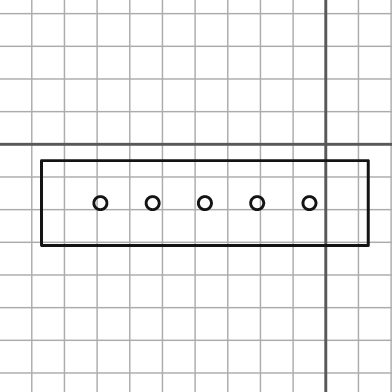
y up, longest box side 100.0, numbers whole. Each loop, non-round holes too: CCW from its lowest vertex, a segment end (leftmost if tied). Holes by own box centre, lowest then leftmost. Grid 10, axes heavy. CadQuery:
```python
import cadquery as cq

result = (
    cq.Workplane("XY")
    .moveTo(-87.0, -31.0)
    .lineTo(13.0, -31.0)
    .lineTo(13.0, -5.0)
    .lineTo(-87.0, -5.0)
    .close()
    .moveTo(-69.0, -18.0)
    .circle(2.0)
    .moveTo(-53.0, -18.0)
    .circle(2.0)
    .moveTo(-37.0, -18.0)
    .circle(2.0)
    .moveTo(-21.0, -18.0)
    .circle(2.0)
    .moveTo(-5.0, -18.0)
    .circle(2.0)
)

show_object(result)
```